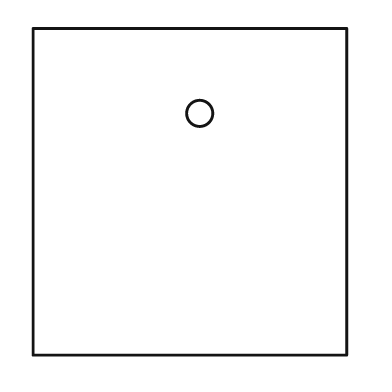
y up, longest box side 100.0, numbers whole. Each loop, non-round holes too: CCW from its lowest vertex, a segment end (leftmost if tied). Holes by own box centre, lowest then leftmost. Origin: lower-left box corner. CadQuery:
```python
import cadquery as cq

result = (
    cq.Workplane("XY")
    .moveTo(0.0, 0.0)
    .lineTo(96.0, 0.0)
    .lineTo(96.0, 100.0)
    .lineTo(0.0, 100.0)
    .close()
    .moveTo(51.0, 74.0)
    .circle(4.0)
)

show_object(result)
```